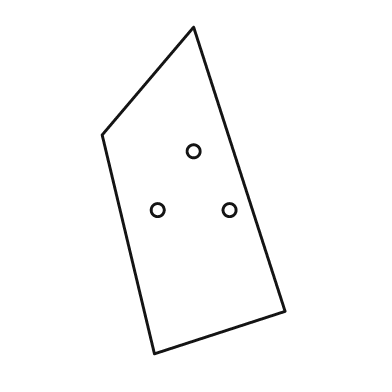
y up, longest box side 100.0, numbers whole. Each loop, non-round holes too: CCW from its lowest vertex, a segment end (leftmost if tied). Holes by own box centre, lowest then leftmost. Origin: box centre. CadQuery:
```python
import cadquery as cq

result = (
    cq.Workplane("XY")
    .moveTo(-12.0, -50.0)
    .lineTo(28.0, -37.0)
    .lineTo(0.0, 50.0)
    .lineTo(-28.0, 17.0)
    .close()
    .moveTo(-11.0, -6.0)
    .circle(2.0)
    .moveTo(11.0, -6.0)
    .circle(2.0)
    .moveTo(0.0, 12.0)
    .circle(2.0)
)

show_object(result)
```